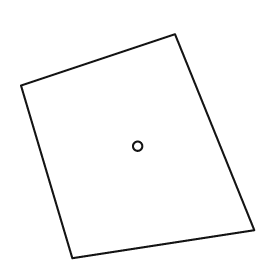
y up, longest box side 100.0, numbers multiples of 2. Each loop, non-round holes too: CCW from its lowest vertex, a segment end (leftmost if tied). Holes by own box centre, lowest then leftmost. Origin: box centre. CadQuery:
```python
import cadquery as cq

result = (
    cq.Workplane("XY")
    .moveTo(-28.0, -48.0)
    .lineTo(50.0, -36.0)
    .lineTo(16.0, 48.0)
    .lineTo(-50.0, 26.0)
    .close()
    .moveTo(0.0, 0.0)
    .circle(2.0)
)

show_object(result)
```